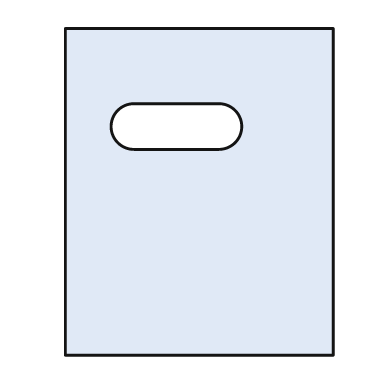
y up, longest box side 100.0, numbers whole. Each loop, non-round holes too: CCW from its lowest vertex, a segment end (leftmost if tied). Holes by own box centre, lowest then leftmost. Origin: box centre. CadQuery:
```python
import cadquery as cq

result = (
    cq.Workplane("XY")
    .moveTo(-41.0, -50.0)
    .lineTo(41.0, -50.0)
    .lineTo(41.0, 50.0)
    .lineTo(-41.0, 50.0)
    .close()
    .moveTo(-20.0, 13.0)
    .lineTo(6.0, 13.0)
    .threePointArc((13.0, 20.0), (6.0, 27.0))
    .lineTo(-20.0, 27.0)
    .threePointArc((-27.0, 20.0), (-20.0, 13.0))
    .close()
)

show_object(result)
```